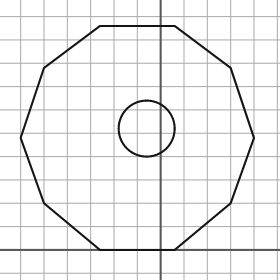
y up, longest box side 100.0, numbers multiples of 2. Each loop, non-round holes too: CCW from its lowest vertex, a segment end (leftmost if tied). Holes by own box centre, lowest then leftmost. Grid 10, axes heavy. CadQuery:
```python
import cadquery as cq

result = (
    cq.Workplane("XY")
    .moveTo(-26.0, 0.0)
    .lineTo(6.0, 0.0)
    .lineTo(30.0, 20.0)
    .lineTo(40.0, 48.0)
    .lineTo(30.0, 78.0)
    .lineTo(6.0, 96.0)
    .lineTo(-26.0, 96.0)
    .lineTo(-50.0, 78.0)
    .lineTo(-60.0, 48.0)
    .lineTo(-50.0, 20.0)
    .close()
    .moveTo(-6.0, 52.0)
    .circle(12.0)
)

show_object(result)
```